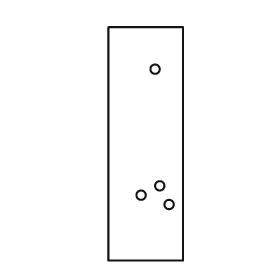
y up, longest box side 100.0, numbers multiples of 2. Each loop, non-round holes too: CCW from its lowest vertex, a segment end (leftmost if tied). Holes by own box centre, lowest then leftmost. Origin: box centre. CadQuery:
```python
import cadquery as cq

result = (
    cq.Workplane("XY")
    .moveTo(-16.0, -50.0)
    .lineTo(16.0, -50.0)
    .lineTo(16.0, 50.0)
    .lineTo(-16.0, 50.0)
    .close()
    .moveTo(10.0, -26.0)
    .circle(2.0)
    .moveTo(-2.0, -22.0)
    .circle(2.0)
    .moveTo(6.0, -18.0)
    .circle(2.0)
    .moveTo(4.0, 32.0)
    .circle(2.0)
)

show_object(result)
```